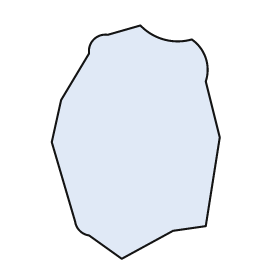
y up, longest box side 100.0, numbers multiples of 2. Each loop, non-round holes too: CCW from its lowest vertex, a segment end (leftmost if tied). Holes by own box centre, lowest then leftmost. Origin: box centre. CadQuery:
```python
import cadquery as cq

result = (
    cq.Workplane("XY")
    .moveTo(-6.0, -50.0)
    .lineTo(16.0, -38.0)
    .lineTo(30.0, -36.0)
    .lineTo(36.0, 2.0)
    .lineTo(30.0, 26.0)
    .threePointArc((30.0, 36.0), (24.0, 44.0))
    .threePointArc((12.0, 44.0), (2.0, 50.0))
    .lineTo(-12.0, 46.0)
    .threePointArc((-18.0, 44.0), (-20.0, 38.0))
    .lineTo(-32.0, 18.0)
    .lineTo(-36.0, 0.0)
    .lineTo(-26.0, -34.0)
    .threePointArc((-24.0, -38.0), (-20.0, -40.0))
    .close()
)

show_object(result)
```